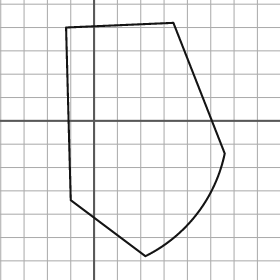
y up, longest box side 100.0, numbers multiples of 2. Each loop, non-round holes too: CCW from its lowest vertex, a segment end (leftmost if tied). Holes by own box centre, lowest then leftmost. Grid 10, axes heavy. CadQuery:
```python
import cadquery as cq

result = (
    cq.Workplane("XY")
    .moveTo(22.0, -58.0)
    .threePointArc((44.0, -40.0), (56.0, -14.0))
    .lineTo(34.0, 42.0)
    .lineTo(-12.0, 40.0)
    .lineTo(-10.0, -34.0)
    .close()
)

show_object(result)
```